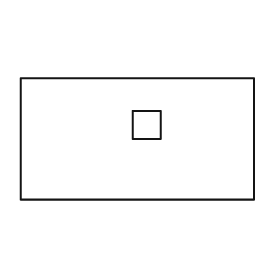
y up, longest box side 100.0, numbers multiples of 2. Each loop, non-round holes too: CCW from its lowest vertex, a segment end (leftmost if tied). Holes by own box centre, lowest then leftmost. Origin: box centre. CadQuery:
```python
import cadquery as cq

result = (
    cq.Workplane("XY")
    .moveTo(-50.0, -26.0)
    .lineTo(50.0, -26.0)
    .lineTo(50.0, 26.0)
    .lineTo(-50.0, 26.0)
    .close()
    .moveTo(-2.0, 0.0)
    .lineTo(10.0, 0.0)
    .lineTo(10.0, 12.0)
    .lineTo(-2.0, 12.0)
    .close()
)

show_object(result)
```